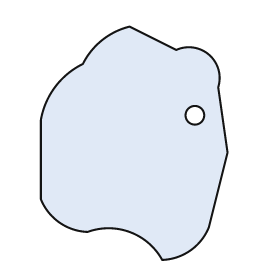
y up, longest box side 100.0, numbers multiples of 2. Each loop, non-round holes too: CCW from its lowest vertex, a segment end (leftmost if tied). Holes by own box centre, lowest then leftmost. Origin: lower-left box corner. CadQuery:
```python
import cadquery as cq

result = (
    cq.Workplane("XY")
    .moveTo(52.0, 0.0)
    .threePointArc((64.0, 4.0), (72.0, 14.0))
    .lineTo(80.0, 46.0)
    .lineTo(76.0, 74.0)
    .threePointArc((72.0, 88.0), (58.0, 90.0))
    .lineTo(38.0, 100.0)
    .threePointArc((26.0, 94.0), (18.0, 84.0))
    .threePointArc((6.0, 74.0), (0.0, 60.0))
    .lineTo(0.0, 26.0)
    .threePointArc((8.0, 16.0), (20.0, 12.0))
    .threePointArc((38.0, 12.0), (52.0, 0.0))
    .close()
    .moveTo(66.0, 62.0)
    .circle(4.0)
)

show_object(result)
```